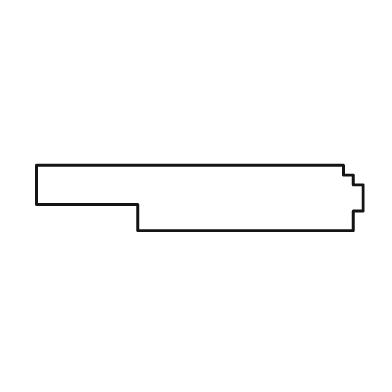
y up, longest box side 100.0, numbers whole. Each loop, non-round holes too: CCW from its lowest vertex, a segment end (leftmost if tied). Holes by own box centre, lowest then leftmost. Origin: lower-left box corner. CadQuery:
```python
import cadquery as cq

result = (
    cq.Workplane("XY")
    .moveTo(31.0, 0.0)
    .lineTo(97.0, 0.0)
    .lineTo(97.0, 6.0)
    .lineTo(100.0, 6.0)
    .lineTo(100.0, 14.0)
    .lineTo(97.0, 14.0)
    .lineTo(97.0, 17.0)
    .lineTo(94.0, 17.0)
    .lineTo(94.0, 20.0)
    .lineTo(0.0, 20.0)
    .lineTo(0.0, 8.0)
    .lineTo(31.0, 8.0)
    .close()
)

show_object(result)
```